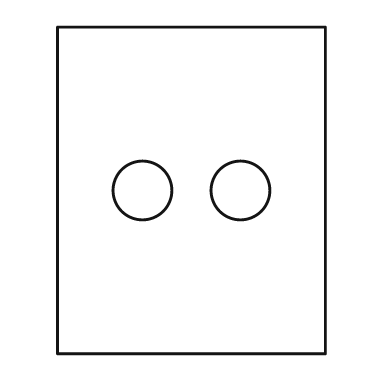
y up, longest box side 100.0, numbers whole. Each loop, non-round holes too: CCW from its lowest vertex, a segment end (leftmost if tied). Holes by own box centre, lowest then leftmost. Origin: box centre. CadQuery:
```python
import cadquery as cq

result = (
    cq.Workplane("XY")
    .moveTo(-41.0, -50.0)
    .lineTo(41.0, -50.0)
    .lineTo(41.0, 50.0)
    .lineTo(-41.0, 50.0)
    .close()
    .moveTo(-15.0, 0.0)
    .circle(9.0)
    .moveTo(15.0, 0.0)
    .circle(9.0)
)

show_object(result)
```